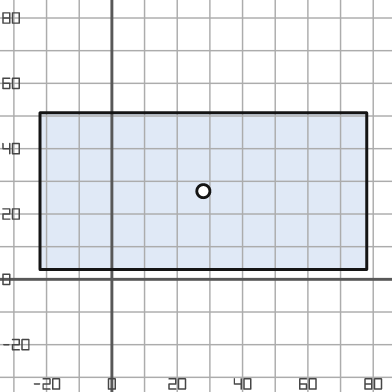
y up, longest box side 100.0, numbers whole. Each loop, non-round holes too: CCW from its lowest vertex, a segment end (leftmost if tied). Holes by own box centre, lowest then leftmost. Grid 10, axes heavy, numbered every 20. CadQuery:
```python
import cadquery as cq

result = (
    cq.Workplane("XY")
    .moveTo(-22.0, 3.0)
    .lineTo(78.0, 3.0)
    .lineTo(78.0, 51.0)
    .lineTo(-22.0, 51.0)
    .close()
    .moveTo(28.0, 27.0)
    .circle(2.0)
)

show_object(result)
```